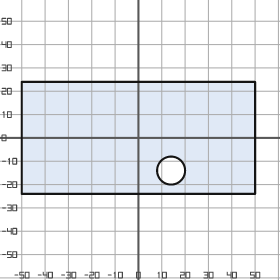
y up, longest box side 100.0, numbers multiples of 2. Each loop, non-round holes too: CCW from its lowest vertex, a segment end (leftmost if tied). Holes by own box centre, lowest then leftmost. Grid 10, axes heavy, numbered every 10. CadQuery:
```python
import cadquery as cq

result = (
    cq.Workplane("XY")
    .moveTo(-50.0, -24.0)
    .lineTo(50.0, -24.0)
    .lineTo(50.0, 24.0)
    .lineTo(-50.0, 24.0)
    .close()
    .moveTo(14.0, -14.0)
    .circle(6.0)
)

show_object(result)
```